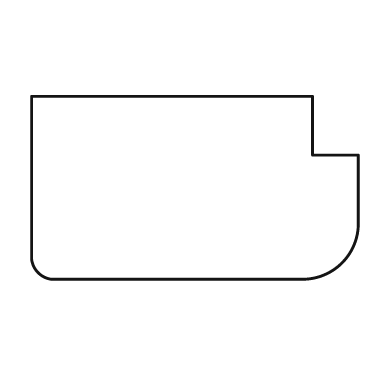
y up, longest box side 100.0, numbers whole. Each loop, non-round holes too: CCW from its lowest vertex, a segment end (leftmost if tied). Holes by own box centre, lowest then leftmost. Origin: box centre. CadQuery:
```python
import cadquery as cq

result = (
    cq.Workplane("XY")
    .moveTo(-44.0, -28.0)
    .lineTo(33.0, -28.0)
    .threePointArc((45.0, -23.0), (50.0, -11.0))
    .lineTo(50.0, 10.0)
    .lineTo(36.0, 10.0)
    .lineTo(36.0, 28.0)
    .lineTo(-50.0, 28.0)
    .lineTo(-50.0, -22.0)
    .threePointArc((-48.0, -26.0), (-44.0, -28.0))
    .close()
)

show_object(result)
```